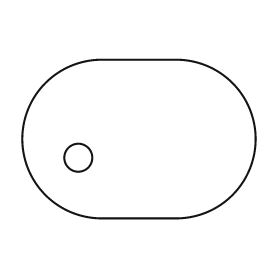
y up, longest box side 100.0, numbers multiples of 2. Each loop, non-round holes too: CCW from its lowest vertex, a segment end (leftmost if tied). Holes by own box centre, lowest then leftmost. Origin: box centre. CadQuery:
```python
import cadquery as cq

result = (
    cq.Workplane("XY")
    .moveTo(-16.0, -34.0)
    .lineTo(16.0, -34.0)
    .threePointArc((50.0, 0.0), (16.0, 34.0))
    .lineTo(-16.0, 34.0)
    .threePointArc((-50.0, 0.0), (-16.0, -34.0))
    .close()
    .moveTo(-26.0, -8.0)
    .circle(6.0)
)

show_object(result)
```